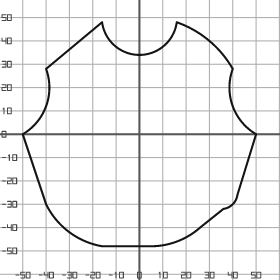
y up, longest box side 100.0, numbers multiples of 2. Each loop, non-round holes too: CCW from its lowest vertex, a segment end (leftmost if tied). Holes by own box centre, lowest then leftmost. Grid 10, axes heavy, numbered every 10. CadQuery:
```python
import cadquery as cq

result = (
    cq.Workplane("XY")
    .moveTo(-16.0, -48.0)
    .lineTo(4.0, -48.0)
    .threePointArc((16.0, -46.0), (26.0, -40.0))
    .lineTo(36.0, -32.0)
    .threePointArc((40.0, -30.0), (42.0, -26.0))
    .lineTo(50.0, 0.0)
    .threePointArc((40.0, 12.0), (40.0, 28.0))
    .threePointArc((30.0, 40.0), (16.0, 48.0))
    .threePointArc((0.0, 34.0), (-16.0, 48.0))
    .lineTo(-40.0, 28.0)
    .threePointArc((-40.0, 12.0), (-50.0, 0.0))
    .lineTo(-40.0, -30.0)
    .threePointArc((-30.0, -42.0), (-16.0, -48.0))
    .close()
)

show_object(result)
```